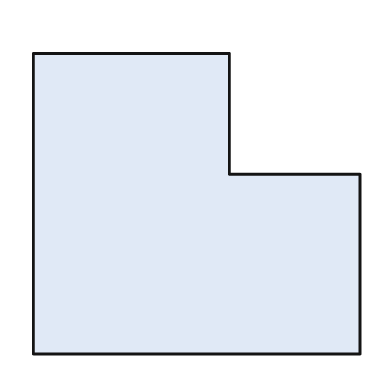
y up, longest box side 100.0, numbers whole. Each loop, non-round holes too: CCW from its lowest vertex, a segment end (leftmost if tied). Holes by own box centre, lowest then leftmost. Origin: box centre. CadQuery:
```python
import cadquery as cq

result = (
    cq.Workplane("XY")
    .moveTo(-50.0, -46.0)
    .lineTo(50.0, -46.0)
    .lineTo(50.0, 9.0)
    .lineTo(10.0, 9.0)
    .lineTo(10.0, 46.0)
    .lineTo(-50.0, 46.0)
    .close()
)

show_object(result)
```